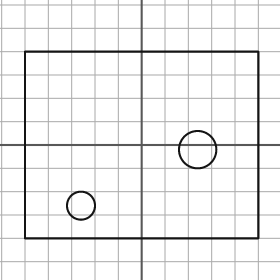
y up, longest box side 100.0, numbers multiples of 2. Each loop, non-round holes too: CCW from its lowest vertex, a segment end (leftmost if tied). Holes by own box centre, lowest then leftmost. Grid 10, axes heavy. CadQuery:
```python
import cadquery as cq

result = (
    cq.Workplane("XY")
    .moveTo(-50.0, -40.0)
    .lineTo(50.0, -40.0)
    .lineTo(50.0, 40.0)
    .lineTo(-50.0, 40.0)
    .close()
    .moveTo(-26.0, -26.0)
    .circle(6.0)
    .moveTo(24.0, -2.0)
    .circle(8.0)
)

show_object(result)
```